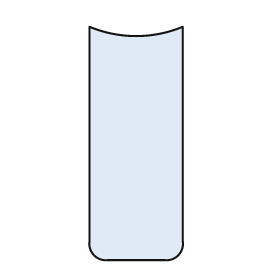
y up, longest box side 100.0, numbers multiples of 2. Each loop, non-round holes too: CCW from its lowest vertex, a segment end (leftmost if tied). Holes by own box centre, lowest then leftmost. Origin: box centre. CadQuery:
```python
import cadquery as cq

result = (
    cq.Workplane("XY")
    .moveTo(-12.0, -50.0)
    .lineTo(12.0, -50.0)
    .threePointArc((18.0, -48.0), (20.0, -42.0))
    .lineTo(20.0, 50.0)
    .threePointArc((0.0, 46.0), (-20.0, 50.0))
    .lineTo(-20.0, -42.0)
    .threePointArc((-18.0, -48.0), (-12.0, -50.0))
    .close()
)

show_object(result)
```